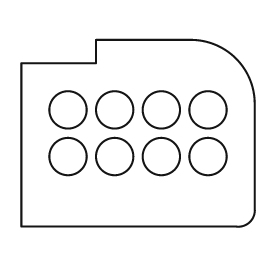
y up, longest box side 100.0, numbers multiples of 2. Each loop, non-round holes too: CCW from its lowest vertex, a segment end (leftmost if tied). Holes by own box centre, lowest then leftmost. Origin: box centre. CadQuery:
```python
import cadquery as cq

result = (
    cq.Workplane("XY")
    .moveTo(-50.0, -40.0)
    .lineTo(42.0, -40.0)
    .threePointArc((48.0, -38.0), (50.0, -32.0))
    .lineTo(50.0, 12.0)
    .threePointArc((42.0, 32.0), (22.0, 40.0))
    .lineTo(-18.0, 40.0)
    .lineTo(-18.0, 30.0)
    .lineTo(-50.0, 30.0)
    .close()
    .moveTo(-30.0, -10.0)
    .circle(8.0)
    .moveTo(-10.0, -10.0)
    .circle(8.0)
    .moveTo(10.0, -10.0)
    .circle(8.0)
    .moveTo(30.0, -10.0)
    .circle(8.0)
    .moveTo(-30.0, 10.0)
    .circle(8.0)
    .moveTo(-10.0, 10.0)
    .circle(8.0)
    .moveTo(10.0, 10.0)
    .circle(8.0)
    .moveTo(30.0, 10.0)
    .circle(8.0)
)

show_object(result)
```